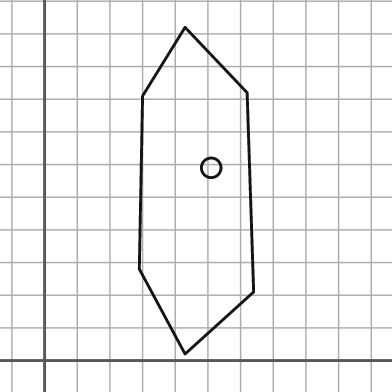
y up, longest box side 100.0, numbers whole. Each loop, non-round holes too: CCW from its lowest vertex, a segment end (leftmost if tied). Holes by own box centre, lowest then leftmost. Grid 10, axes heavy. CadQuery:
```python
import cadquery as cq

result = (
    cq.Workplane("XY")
    .moveTo(43.0, 2.0)
    .lineTo(64.0, 21.0)
    .lineTo(62.0, 82.0)
    .lineTo(43.0, 102.0)
    .lineTo(30.0, 81.0)
    .lineTo(29.0, 28.0)
    .close()
    .moveTo(51.0, 59.0)
    .circle(3.0)
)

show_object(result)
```